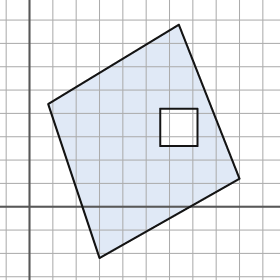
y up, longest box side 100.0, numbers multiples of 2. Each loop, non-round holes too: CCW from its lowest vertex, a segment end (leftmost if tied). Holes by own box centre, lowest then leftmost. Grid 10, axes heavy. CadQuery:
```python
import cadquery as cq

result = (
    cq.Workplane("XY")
    .moveTo(30.0, -22.0)
    .lineTo(90.0, 12.0)
    .lineTo(64.0, 78.0)
    .lineTo(8.0, 44.0)
    .close()
    .moveTo(56.0, 26.0)
    .lineTo(72.0, 26.0)
    .lineTo(72.0, 42.0)
    .lineTo(56.0, 42.0)
    .close()
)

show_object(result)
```